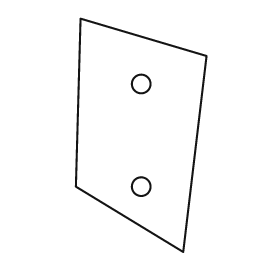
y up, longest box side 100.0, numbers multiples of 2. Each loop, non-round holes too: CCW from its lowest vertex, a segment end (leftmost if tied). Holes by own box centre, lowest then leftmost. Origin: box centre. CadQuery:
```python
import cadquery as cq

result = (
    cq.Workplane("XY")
    .moveTo(18.0, -50.0)
    .lineTo(28.0, 34.0)
    .lineTo(-26.0, 50.0)
    .lineTo(-28.0, -22.0)
    .close()
    .moveTo(0.0, -22.0)
    .circle(4.0)
    .moveTo(0.0, 22.0)
    .circle(4.0)
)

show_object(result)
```